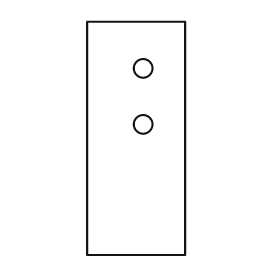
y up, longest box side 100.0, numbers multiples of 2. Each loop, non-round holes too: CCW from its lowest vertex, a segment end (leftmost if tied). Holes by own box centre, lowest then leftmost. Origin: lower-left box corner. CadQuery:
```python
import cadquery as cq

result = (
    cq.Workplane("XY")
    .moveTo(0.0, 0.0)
    .lineTo(42.0, 0.0)
    .lineTo(42.0, 100.0)
    .lineTo(0.0, 100.0)
    .close()
    .moveTo(24.0, 56.0)
    .circle(4.0)
    .moveTo(24.0, 80.0)
    .circle(4.0)
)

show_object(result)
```